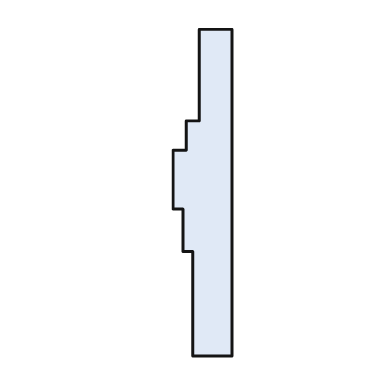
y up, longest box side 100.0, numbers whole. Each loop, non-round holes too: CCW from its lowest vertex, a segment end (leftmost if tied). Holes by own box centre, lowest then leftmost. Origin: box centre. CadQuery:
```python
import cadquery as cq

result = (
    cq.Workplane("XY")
    .moveTo(-3.0, -50.0)
    .lineTo(9.0, -50.0)
    .lineTo(9.0, 50.0)
    .lineTo(-1.0, 50.0)
    .lineTo(-1.0, 22.0)
    .lineTo(-5.0, 22.0)
    .lineTo(-5.0, 13.0)
    .lineTo(-9.0, 13.0)
    .lineTo(-9.0, -5.0)
    .lineTo(-6.0, -5.0)
    .lineTo(-6.0, -18.0)
    .lineTo(-3.0, -18.0)
    .close()
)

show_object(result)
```